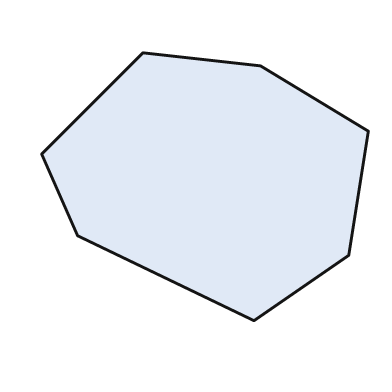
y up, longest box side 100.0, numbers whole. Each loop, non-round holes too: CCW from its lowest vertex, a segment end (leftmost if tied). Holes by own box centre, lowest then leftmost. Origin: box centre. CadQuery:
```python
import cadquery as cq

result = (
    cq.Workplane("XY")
    .moveTo(15.0, -41.0)
    .lineTo(44.0, -21.0)
    .lineTo(50.0, 17.0)
    .lineTo(17.0, 37.0)
    .lineTo(-19.0, 41.0)
    .lineTo(-50.0, 10.0)
    .lineTo(-39.0, -15.0)
    .close()
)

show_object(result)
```